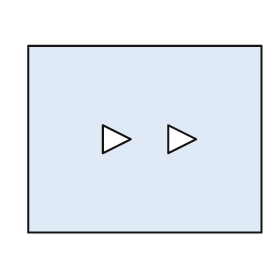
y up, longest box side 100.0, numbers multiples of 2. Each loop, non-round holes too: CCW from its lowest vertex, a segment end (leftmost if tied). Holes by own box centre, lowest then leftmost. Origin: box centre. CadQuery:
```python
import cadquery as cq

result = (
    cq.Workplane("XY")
    .moveTo(-50.0, -40.0)
    .lineTo(50.0, -40.0)
    .lineTo(50.0, 40.0)
    .lineTo(-50.0, 40.0)
    .close()
    .moveTo(-18.0, -6.0)
    .lineTo(-6.0, 0.0)
    .lineTo(-18.0, 6.0)
    .close()
    .moveTo(10.0, -6.0)
    .lineTo(22.0, 0.0)
    .lineTo(10.0, 6.0)
    .close()
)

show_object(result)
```